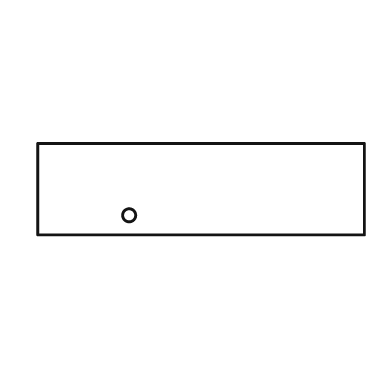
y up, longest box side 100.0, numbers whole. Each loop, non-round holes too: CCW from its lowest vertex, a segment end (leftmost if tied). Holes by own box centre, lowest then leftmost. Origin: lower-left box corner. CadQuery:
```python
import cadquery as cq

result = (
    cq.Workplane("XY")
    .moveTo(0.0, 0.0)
    .lineTo(100.0, 0.0)
    .lineTo(100.0, 28.0)
    .lineTo(0.0, 28.0)
    .close()
    .moveTo(28.0, 6.0)
    .circle(2.0)
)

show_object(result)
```